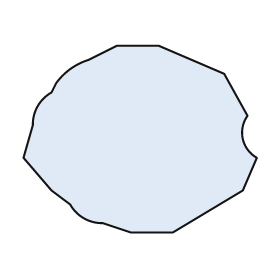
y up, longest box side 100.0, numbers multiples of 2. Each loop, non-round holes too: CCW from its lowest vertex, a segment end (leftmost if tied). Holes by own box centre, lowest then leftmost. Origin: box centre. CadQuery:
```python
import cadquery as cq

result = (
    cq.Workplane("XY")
    .moveTo(-4.0, -40.0)
    .lineTo(14.0, -40.0)
    .lineTo(44.0, -22.0)
    .lineTo(50.0, -8.0)
    .threePointArc((44.0, 0.0), (46.0, 10.0))
    .lineTo(36.0, 28.0)
    .lineTo(8.0, 40.0)
    .lineTo(-10.0, 40.0)
    .lineTo(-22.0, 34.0)
    .threePointArc((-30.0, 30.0), (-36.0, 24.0))
    .lineTo(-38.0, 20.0)
    .threePointArc((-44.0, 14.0), (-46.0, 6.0))
    .lineTo(-50.0, -8.0)
    .lineTo(-38.0, -22.0)
    .lineTo(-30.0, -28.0)
    .threePointArc((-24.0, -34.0), (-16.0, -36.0))
    .close()
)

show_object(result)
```